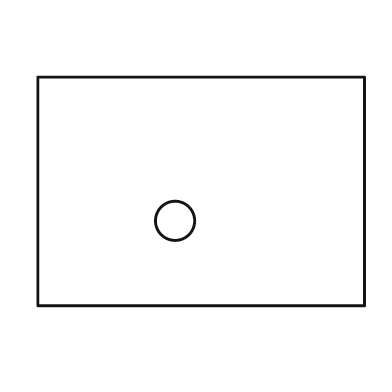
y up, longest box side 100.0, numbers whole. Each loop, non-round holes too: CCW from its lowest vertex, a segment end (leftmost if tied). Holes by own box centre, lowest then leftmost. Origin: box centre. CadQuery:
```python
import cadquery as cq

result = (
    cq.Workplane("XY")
    .moveTo(-50.0, -35.0)
    .lineTo(50.0, -35.0)
    .lineTo(50.0, 35.0)
    .lineTo(-50.0, 35.0)
    .close()
    .moveTo(-8.0, -9.0)
    .circle(6.0)
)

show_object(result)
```